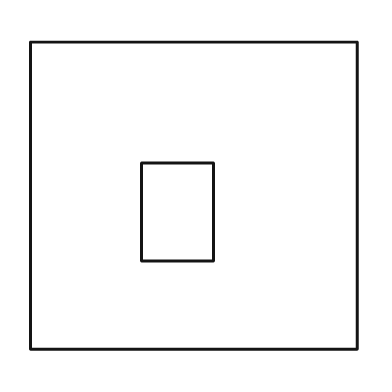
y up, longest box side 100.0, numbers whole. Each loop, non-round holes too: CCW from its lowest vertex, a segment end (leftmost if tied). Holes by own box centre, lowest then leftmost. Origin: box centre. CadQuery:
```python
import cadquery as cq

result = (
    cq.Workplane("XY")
    .moveTo(-50.0, -47.0)
    .lineTo(50.0, -47.0)
    .lineTo(50.0, 47.0)
    .lineTo(-50.0, 47.0)
    .close()
    .moveTo(-16.0, -20.0)
    .lineTo(6.0, -20.0)
    .lineTo(6.0, 10.0)
    .lineTo(-16.0, 10.0)
    .close()
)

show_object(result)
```